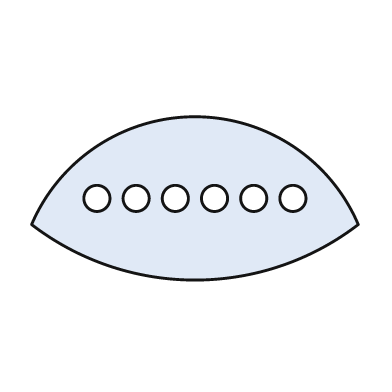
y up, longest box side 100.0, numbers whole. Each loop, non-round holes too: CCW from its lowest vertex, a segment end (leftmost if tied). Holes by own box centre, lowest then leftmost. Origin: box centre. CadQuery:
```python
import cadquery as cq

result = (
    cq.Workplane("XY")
    .moveTo(-50.0, -8.0)
    .threePointArc((0.0, -25.0), (50.0, -8.0))
    .threePointArc((0.0, 25.0), (-50.0, -8.0))
    .close()
    .moveTo(-30.0, 0.0)
    .circle(4.0)
    .moveTo(-18.0, 0.0)
    .circle(4.0)
    .moveTo(-6.0, 0.0)
    .circle(4.0)
    .moveTo(6.0, 0.0)
    .circle(4.0)
    .moveTo(18.0, 0.0)
    .circle(4.0)
    .moveTo(30.0, 0.0)
    .circle(4.0)
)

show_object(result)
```